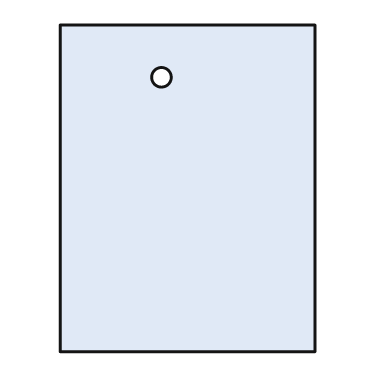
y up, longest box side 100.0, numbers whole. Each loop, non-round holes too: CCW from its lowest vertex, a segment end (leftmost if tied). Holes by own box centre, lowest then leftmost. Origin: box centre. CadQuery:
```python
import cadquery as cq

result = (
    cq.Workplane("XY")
    .moveTo(-39.0, -50.0)
    .lineTo(39.0, -50.0)
    .lineTo(39.0, 50.0)
    .lineTo(-39.0, 50.0)
    .close()
    .moveTo(-8.0, 34.0)
    .circle(3.0)
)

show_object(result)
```